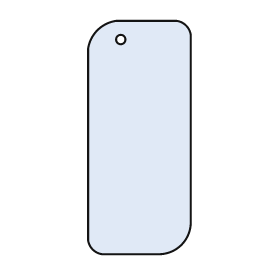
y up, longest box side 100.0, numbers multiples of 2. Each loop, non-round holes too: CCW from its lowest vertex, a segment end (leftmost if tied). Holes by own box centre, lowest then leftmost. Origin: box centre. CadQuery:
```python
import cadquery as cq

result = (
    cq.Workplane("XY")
    .moveTo(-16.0, -50.0)
    .lineTo(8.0, -50.0)
    .threePointArc((18.0, -46.0), (22.0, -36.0))
    .lineTo(22.0, 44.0)
    .threePointArc((20.0, 48.0), (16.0, 50.0))
    .lineTo(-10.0, 50.0)
    .threePointArc((-18.0, 46.0), (-22.0, 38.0))
    .lineTo(-22.0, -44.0)
    .threePointArc((-20.0, -48.0), (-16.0, -50.0))
    .close()
    .moveTo(-8.0, 42.0)
    .circle(2.0)
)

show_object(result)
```